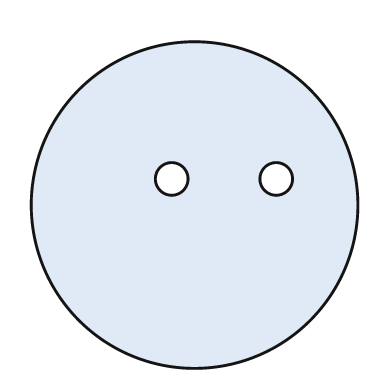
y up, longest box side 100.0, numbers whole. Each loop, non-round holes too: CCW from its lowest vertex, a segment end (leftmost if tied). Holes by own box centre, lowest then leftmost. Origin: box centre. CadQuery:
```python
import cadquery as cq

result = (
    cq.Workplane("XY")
    .moveTo(0.0, 0.0)
    .circle(50.0)
    .moveTo(-7.0, 8.0)
    .circle(5.0)
    .moveTo(25.0, 8.0)
    .circle(5.0)
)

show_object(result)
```